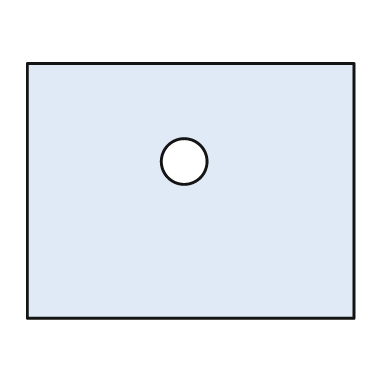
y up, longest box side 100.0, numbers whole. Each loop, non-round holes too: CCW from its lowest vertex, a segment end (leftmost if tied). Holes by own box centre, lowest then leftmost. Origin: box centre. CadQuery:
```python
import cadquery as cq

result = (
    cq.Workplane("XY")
    .moveTo(-50.0, -39.0)
    .lineTo(50.0, -39.0)
    .lineTo(50.0, 39.0)
    .lineTo(-50.0, 39.0)
    .close()
    .moveTo(-2.0, 9.0)
    .circle(7.0)
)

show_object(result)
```